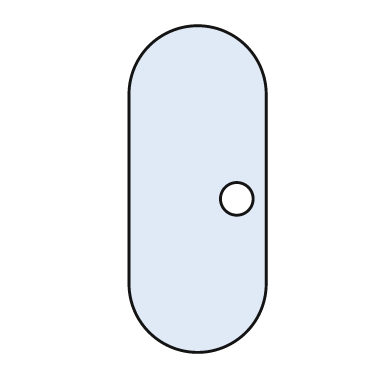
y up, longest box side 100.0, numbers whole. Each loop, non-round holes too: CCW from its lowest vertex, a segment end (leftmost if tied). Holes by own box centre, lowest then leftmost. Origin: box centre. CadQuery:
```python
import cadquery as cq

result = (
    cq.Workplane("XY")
    .moveTo(-21.0, -29.0)
    .threePointArc((0.0, -50.0), (21.0, -29.0))
    .lineTo(21.0, 29.0)
    .threePointArc((0.0, 50.0), (-21.0, 29.0))
    .close()
    .moveTo(12.0, -3.0)
    .circle(5.0)
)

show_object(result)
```